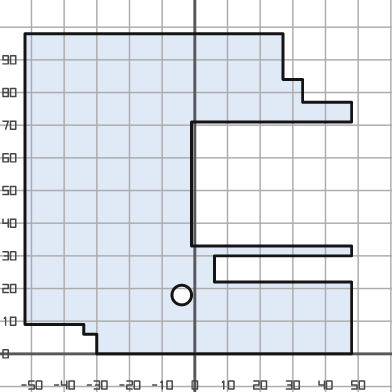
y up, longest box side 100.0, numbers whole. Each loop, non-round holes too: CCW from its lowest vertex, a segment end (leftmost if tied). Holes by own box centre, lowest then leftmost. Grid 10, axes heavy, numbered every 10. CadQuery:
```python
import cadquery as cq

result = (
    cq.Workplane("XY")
    .moveTo(-30.0, 0.0)
    .lineTo(48.0, 0.0)
    .lineTo(48.0, 22.0)
    .lineTo(6.0, 22.0)
    .lineTo(6.0, 30.0)
    .lineTo(48.0, 30.0)
    .lineTo(48.0, 33.0)
    .lineTo(-1.0, 33.0)
    .lineTo(-1.0, 71.0)
    .lineTo(48.0, 71.0)
    .lineTo(48.0, 77.0)
    .lineTo(33.0, 77.0)
    .lineTo(33.0, 84.0)
    .lineTo(27.0, 84.0)
    .lineTo(27.0, 98.0)
    .lineTo(-52.0, 98.0)
    .lineTo(-52.0, 9.0)
    .lineTo(-34.0, 9.0)
    .lineTo(-34.0, 6.0)
    .lineTo(-30.0, 6.0)
    .close()
    .moveTo(-4.0, 18.0)
    .circle(3.0)
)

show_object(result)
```